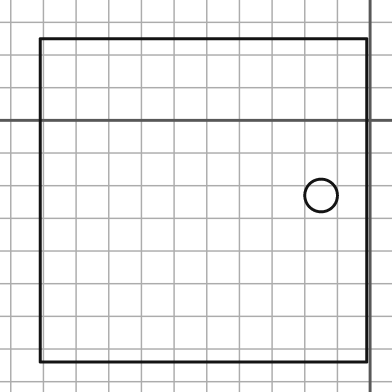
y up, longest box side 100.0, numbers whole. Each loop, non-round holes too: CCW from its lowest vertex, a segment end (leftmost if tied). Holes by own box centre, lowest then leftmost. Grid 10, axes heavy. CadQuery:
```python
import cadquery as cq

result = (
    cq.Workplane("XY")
    .moveTo(-101.0, -74.0)
    .lineTo(-1.0, -74.0)
    .lineTo(-1.0, 25.0)
    .lineTo(-101.0, 25.0)
    .close()
    .moveTo(-15.0, -23.0)
    .circle(5.0)
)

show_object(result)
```